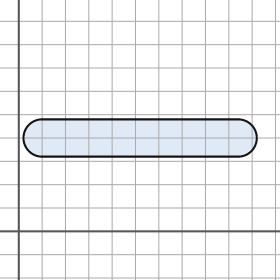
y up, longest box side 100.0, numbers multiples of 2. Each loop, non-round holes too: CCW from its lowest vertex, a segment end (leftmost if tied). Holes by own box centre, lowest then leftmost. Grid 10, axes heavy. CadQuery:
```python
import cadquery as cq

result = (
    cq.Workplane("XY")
    .moveTo(10.0, 32.0)
    .lineTo(94.0, 32.0)
    .threePointArc((102.0, 40.0), (94.0, 48.0))
    .lineTo(10.0, 48.0)
    .threePointArc((2.0, 40.0), (10.0, 32.0))
    .close()
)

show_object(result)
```